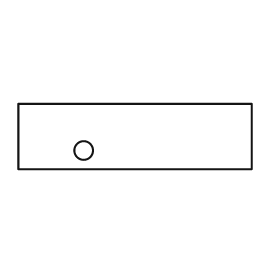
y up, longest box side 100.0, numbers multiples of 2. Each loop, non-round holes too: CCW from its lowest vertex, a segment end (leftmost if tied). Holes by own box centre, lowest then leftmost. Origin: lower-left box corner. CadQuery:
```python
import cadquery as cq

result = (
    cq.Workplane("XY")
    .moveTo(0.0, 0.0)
    .lineTo(100.0, 0.0)
    .lineTo(100.0, 28.0)
    .lineTo(0.0, 28.0)
    .close()
    .moveTo(28.0, 8.0)
    .circle(4.0)
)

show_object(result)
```